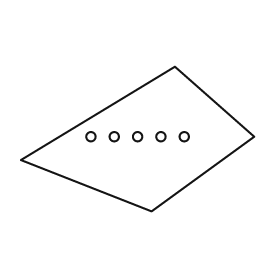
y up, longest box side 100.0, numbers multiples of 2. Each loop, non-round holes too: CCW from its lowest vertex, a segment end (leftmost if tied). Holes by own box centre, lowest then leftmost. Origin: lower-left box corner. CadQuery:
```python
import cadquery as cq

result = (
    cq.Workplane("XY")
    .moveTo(56.0, 0.0)
    .lineTo(100.0, 32.0)
    .lineTo(66.0, 62.0)
    .lineTo(0.0, 22.0)
    .close()
    .moveTo(30.0, 32.0)
    .circle(2.0)
    .moveTo(40.0, 32.0)
    .circle(2.0)
    .moveTo(50.0, 32.0)
    .circle(2.0)
    .moveTo(60.0, 32.0)
    .circle(2.0)
    .moveTo(70.0, 32.0)
    .circle(2.0)
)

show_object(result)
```